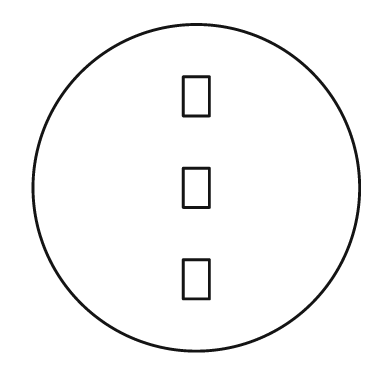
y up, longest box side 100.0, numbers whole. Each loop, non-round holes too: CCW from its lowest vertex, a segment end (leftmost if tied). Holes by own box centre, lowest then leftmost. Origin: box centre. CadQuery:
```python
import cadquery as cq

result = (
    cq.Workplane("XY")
    .moveTo(0.0, 0.0)
    .circle(50.0)
    .moveTo(-4.0, -34.0)
    .lineTo(4.0, -34.0)
    .lineTo(4.0, -22.0)
    .lineTo(-4.0, -22.0)
    .close()
    .moveTo(-4.0, -6.0)
    .lineTo(4.0, -6.0)
    .lineTo(4.0, 6.0)
    .lineTo(-4.0, 6.0)
    .close()
    .moveTo(-4.0, 22.0)
    .lineTo(4.0, 22.0)
    .lineTo(4.0, 34.0)
    .lineTo(-4.0, 34.0)
    .close()
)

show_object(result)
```